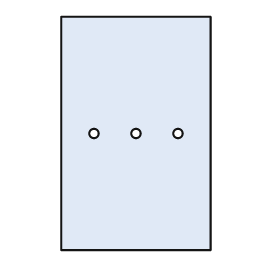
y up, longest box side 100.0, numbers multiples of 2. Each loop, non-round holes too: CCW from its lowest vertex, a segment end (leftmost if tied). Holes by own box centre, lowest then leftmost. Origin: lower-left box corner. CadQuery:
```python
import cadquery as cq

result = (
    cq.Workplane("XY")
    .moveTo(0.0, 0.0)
    .lineTo(64.0, 0.0)
    .lineTo(64.0, 100.0)
    .lineTo(0.0, 100.0)
    .close()
    .moveTo(14.0, 50.0)
    .circle(2.0)
    .moveTo(32.0, 50.0)
    .circle(2.0)
    .moveTo(50.0, 50.0)
    .circle(2.0)
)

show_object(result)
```